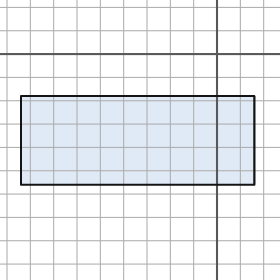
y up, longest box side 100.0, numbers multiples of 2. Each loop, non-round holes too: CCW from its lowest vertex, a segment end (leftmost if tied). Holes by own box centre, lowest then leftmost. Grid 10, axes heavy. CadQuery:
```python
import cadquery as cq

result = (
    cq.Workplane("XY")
    .moveTo(-84.0, -56.0)
    .lineTo(16.0, -56.0)
    .lineTo(16.0, -18.0)
    .lineTo(-84.0, -18.0)
    .close()
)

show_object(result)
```